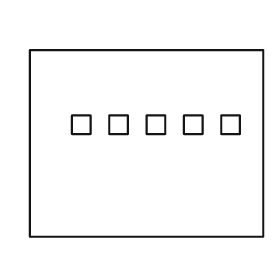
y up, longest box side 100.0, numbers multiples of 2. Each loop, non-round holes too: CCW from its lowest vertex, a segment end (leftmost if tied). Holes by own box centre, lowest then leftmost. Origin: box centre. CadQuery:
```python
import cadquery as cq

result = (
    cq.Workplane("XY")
    .moveTo(-50.0, -40.0)
    .lineTo(50.0, -40.0)
    .lineTo(50.0, 40.0)
    .lineTo(-50.0, 40.0)
    .close()
    .moveTo(-32.0, 4.0)
    .lineTo(-24.0, 4.0)
    .lineTo(-24.0, 12.0)
    .lineTo(-32.0, 12.0)
    .close()
    .moveTo(-16.0, 4.0)
    .lineTo(-8.0, 4.0)
    .lineTo(-8.0, 12.0)
    .lineTo(-16.0, 12.0)
    .close()
    .moveTo(0.0, 4.0)
    .lineTo(8.0, 4.0)
    .lineTo(8.0, 12.0)
    .lineTo(0.0, 12.0)
    .close()
    .moveTo(16.0, 4.0)
    .lineTo(24.0, 4.0)
    .lineTo(24.0, 12.0)
    .lineTo(16.0, 12.0)
    .close()
    .moveTo(32.0, 4.0)
    .lineTo(40.0, 4.0)
    .lineTo(40.0, 12.0)
    .lineTo(32.0, 12.0)
    .close()
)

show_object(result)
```